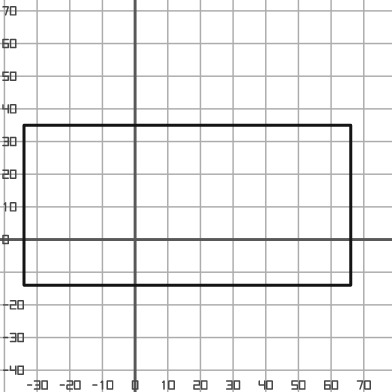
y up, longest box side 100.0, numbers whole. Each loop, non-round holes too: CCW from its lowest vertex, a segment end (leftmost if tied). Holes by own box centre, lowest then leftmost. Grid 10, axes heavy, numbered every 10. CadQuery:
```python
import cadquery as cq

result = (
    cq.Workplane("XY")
    .moveTo(-34.0, -14.0)
    .lineTo(66.0, -14.0)
    .lineTo(66.0, 35.0)
    .lineTo(-34.0, 35.0)
    .close()
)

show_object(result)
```